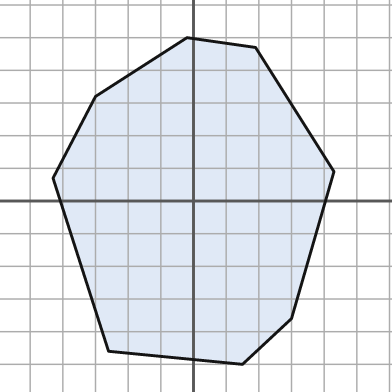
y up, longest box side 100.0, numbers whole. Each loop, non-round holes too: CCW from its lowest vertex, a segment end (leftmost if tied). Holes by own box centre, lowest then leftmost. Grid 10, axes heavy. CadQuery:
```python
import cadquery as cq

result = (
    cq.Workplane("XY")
    .moveTo(15.0, -50.0)
    .lineTo(30.0, -36.0)
    .lineTo(43.0, 9.0)
    .lineTo(19.0, 47.0)
    .lineTo(-2.0, 50.0)
    .lineTo(-30.0, 32.0)
    .lineTo(-43.0, 7.0)
    .lineTo(-26.0, -46.0)
    .close()
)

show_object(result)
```